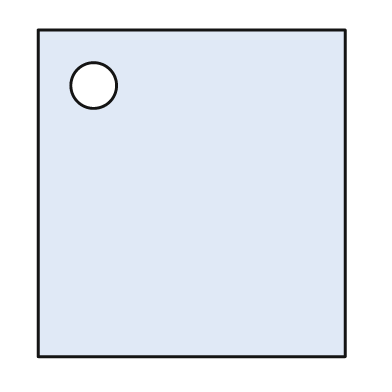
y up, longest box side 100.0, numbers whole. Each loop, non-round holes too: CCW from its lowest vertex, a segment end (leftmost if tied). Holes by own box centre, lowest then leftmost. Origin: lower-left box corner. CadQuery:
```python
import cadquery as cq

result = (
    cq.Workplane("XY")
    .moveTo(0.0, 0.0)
    .lineTo(94.0, 0.0)
    .lineTo(94.0, 100.0)
    .lineTo(0.0, 100.0)
    .close()
    .moveTo(17.0, 83.0)
    .circle(7.0)
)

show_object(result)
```